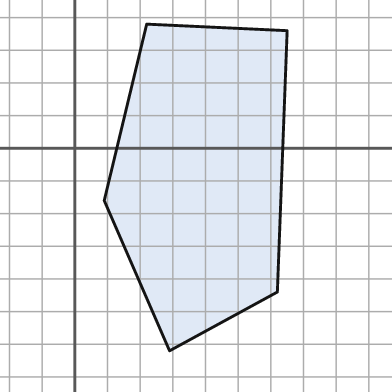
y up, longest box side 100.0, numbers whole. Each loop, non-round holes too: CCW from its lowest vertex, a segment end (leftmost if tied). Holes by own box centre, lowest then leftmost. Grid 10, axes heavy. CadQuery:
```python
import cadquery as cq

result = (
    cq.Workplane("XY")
    .moveTo(29.0, -62.0)
    .lineTo(62.0, -44.0)
    .lineTo(65.0, 36.0)
    .lineTo(22.0, 38.0)
    .lineTo(9.0, -16.0)
    .close()
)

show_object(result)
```